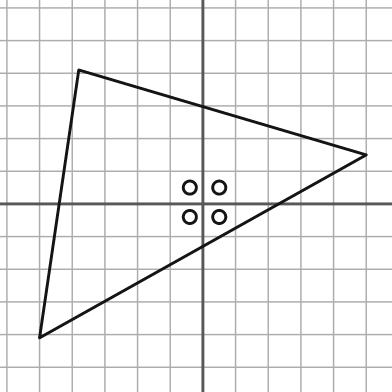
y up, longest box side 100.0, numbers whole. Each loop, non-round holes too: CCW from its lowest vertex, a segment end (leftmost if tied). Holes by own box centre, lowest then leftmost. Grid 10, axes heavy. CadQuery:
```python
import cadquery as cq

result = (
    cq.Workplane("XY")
    .moveTo(-50.0, -41.0)
    .lineTo(50.0, 15.0)
    .lineTo(-38.0, 41.0)
    .close()
    .moveTo(-4.0, -4.0)
    .circle(2.0)
    .moveTo(5.0, -4.0)
    .circle(2.0)
    .moveTo(-4.0, 5.0)
    .circle(2.0)
    .moveTo(5.0, 5.0)
    .circle(2.0)
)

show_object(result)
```